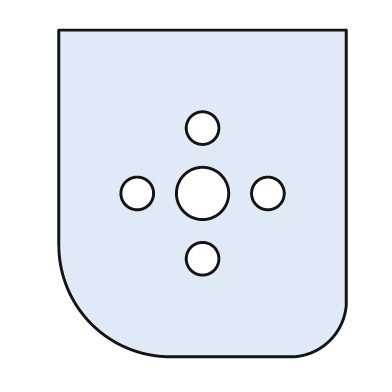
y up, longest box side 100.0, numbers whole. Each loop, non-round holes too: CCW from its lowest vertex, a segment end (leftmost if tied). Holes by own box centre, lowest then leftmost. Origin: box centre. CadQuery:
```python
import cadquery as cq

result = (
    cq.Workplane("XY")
    .moveTo(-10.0, -50.0)
    .lineTo(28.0, -50.0)
    .threePointArc((39.0, -45.0), (44.0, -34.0))
    .lineTo(44.0, 50.0)
    .lineTo(-44.0, 50.0)
    .lineTo(-44.0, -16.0)
    .threePointArc((-34.0, -40.0), (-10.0, -50.0))
    .close()
    .moveTo(0.0, -20.0)
    .circle(5.0)
    .moveTo(-20.0, 0.0)
    .circle(5.0)
    .moveTo(0.0, 0.0)
    .circle(8.0)
    .moveTo(20.0, 0.0)
    .circle(5.0)
    .moveTo(0.0, 20.0)
    .circle(5.0)
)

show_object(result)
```